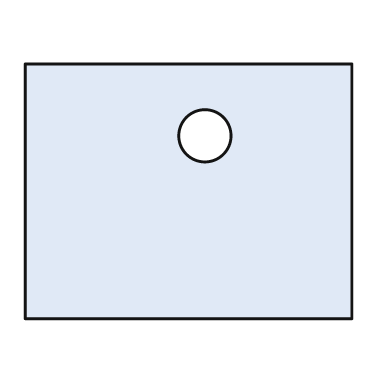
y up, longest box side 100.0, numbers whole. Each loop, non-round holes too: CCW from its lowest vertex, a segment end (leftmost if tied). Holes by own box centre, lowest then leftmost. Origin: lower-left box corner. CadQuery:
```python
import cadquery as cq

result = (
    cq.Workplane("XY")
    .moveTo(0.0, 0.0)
    .lineTo(100.0, 0.0)
    .lineTo(100.0, 78.0)
    .lineTo(0.0, 78.0)
    .close()
    .moveTo(55.0, 56.0)
    .circle(8.0)
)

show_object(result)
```